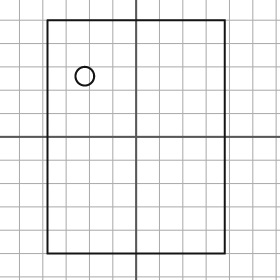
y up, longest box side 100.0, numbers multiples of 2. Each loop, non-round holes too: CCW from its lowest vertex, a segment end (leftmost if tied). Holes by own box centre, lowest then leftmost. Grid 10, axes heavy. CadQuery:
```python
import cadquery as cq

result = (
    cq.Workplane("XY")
    .moveTo(-38.0, -50.0)
    .lineTo(38.0, -50.0)
    .lineTo(38.0, 50.0)
    .lineTo(-38.0, 50.0)
    .close()
    .moveTo(-22.0, 26.0)
    .circle(4.0)
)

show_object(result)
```